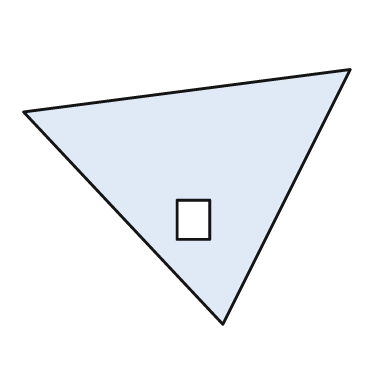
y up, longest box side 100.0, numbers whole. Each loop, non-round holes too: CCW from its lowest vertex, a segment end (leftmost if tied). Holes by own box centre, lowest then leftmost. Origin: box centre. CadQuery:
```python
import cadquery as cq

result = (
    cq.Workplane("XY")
    .moveTo(11.0, -39.0)
    .lineTo(50.0, 39.0)
    .lineTo(-50.0, 26.0)
    .close()
    .moveTo(-3.0, -13.0)
    .lineTo(7.0, -13.0)
    .lineTo(7.0, -1.0)
    .lineTo(-3.0, -1.0)
    .close()
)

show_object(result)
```